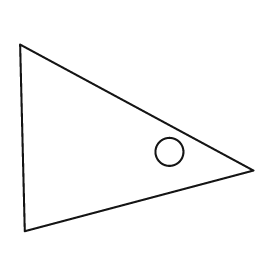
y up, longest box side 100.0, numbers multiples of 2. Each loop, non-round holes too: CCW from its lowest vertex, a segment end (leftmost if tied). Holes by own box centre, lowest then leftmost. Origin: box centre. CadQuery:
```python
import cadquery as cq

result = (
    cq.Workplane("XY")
    .moveTo(-48.0, -40.0)
    .lineTo(50.0, -14.0)
    .lineTo(-50.0, 40.0)
    .close()
    .moveTo(14.0, -6.0)
    .circle(6.0)
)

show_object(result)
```